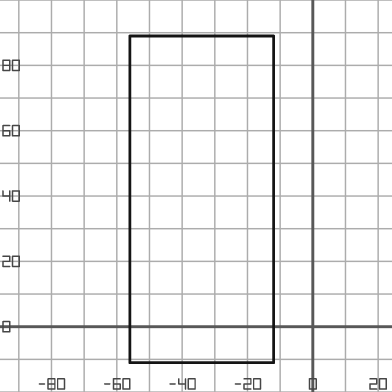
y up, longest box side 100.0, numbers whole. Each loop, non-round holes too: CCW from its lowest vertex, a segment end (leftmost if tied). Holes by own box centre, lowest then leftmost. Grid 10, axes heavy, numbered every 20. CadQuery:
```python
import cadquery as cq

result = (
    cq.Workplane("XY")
    .moveTo(-56.0, -11.0)
    .lineTo(-12.0, -11.0)
    .lineTo(-12.0, 89.0)
    .lineTo(-56.0, 89.0)
    .close()
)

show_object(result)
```